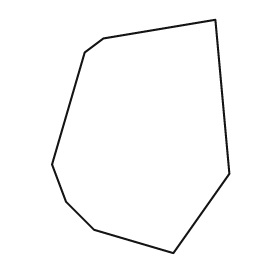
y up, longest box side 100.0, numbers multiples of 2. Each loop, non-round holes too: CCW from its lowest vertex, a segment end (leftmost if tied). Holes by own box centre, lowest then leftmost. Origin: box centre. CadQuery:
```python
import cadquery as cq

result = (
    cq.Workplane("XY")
    .moveTo(14.0, -50.0)
    .lineTo(38.0, -16.0)
    .lineTo(32.0, 50.0)
    .lineTo(-16.0, 42.0)
    .lineTo(-24.0, 36.0)
    .lineTo(-38.0, -12.0)
    .lineTo(-32.0, -28.0)
    .lineTo(-20.0, -40.0)
    .close()
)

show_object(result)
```